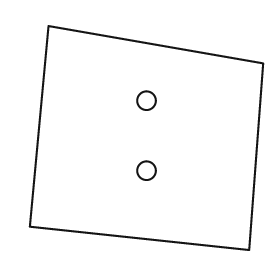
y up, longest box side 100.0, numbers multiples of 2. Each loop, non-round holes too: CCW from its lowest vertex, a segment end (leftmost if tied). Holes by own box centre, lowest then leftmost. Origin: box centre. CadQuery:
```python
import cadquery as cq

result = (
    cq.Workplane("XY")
    .moveTo(44.0, -48.0)
    .lineTo(50.0, 32.0)
    .lineTo(-42.0, 48.0)
    .lineTo(-50.0, -38.0)
    .close()
    .moveTo(0.0, -14.0)
    .circle(4.0)
    .moveTo(0.0, 16.0)
    .circle(4.0)
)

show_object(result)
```